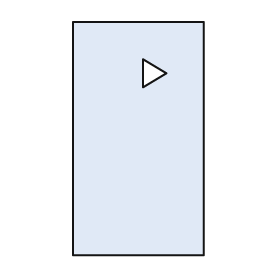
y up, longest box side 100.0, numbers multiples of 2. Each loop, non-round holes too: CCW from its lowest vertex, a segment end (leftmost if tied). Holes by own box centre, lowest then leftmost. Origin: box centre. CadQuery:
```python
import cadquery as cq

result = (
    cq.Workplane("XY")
    .moveTo(-28.0, -50.0)
    .lineTo(28.0, -50.0)
    .lineTo(28.0, 50.0)
    .lineTo(-28.0, 50.0)
    .close()
    .moveTo(2.0, 22.0)
    .lineTo(12.0, 28.0)
    .lineTo(2.0, 34.0)
    .close()
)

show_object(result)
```